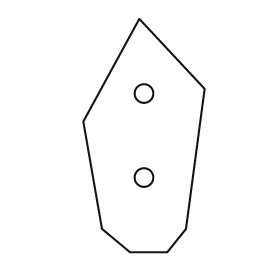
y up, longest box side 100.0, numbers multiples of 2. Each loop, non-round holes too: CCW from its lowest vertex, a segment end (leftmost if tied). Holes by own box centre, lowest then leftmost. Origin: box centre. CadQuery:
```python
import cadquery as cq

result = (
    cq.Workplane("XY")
    .moveTo(-6.0, -50.0)
    .lineTo(10.0, -50.0)
    .lineTo(18.0, -40.0)
    .lineTo(26.0, 20.0)
    .lineTo(-2.0, 50.0)
    .lineTo(-26.0, 6.0)
    .lineTo(-18.0, -40.0)
    .close()
    .moveTo(0.0, -18.0)
    .circle(4.0)
    .moveTo(0.0, 18.0)
    .circle(4.0)
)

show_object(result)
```